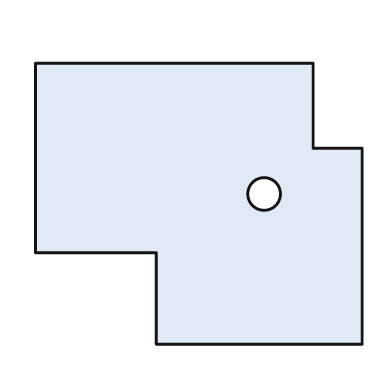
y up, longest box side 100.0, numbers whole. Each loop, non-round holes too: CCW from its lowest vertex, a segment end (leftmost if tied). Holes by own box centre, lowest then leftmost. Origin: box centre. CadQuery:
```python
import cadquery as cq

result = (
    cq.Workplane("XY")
    .moveTo(-13.0, -43.0)
    .lineTo(50.0, -43.0)
    .lineTo(50.0, 17.0)
    .lineTo(35.0, 17.0)
    .lineTo(35.0, 43.0)
    .lineTo(-50.0, 43.0)
    .lineTo(-50.0, -15.0)
    .lineTo(-13.0, -15.0)
    .close()
    .moveTo(20.0, 3.0)
    .circle(5.0)
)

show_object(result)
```